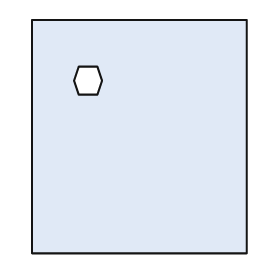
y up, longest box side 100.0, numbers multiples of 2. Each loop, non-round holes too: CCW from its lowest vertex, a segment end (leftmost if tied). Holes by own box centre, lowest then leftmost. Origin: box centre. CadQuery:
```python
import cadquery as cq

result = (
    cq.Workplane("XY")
    .moveTo(-46.0, -50.0)
    .lineTo(46.0, -50.0)
    .lineTo(46.0, 50.0)
    .lineTo(-46.0, 50.0)
    .close()
    .moveTo(-26.0, 18.0)
    .lineTo(-18.0, 18.0)
    .lineTo(-16.0, 24.0)
    .lineTo(-18.0, 30.0)
    .lineTo(-26.0, 30.0)
    .lineTo(-28.0, 24.0)
    .close()
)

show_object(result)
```